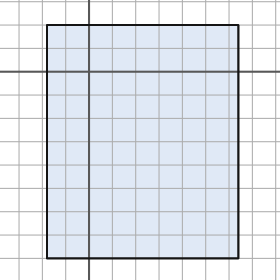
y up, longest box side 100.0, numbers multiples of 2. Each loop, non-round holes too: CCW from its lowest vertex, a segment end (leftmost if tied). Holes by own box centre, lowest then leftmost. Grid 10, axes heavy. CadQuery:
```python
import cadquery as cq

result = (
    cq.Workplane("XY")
    .moveTo(-18.0, -80.0)
    .lineTo(64.0, -80.0)
    .lineTo(64.0, 20.0)
    .lineTo(-18.0, 20.0)
    .close()
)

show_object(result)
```